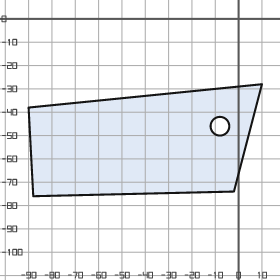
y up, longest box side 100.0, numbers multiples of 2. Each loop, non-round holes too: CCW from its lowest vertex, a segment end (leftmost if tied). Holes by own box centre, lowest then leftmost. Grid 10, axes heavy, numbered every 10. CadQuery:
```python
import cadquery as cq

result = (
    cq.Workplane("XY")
    .moveTo(-88.0, -76.0)
    .lineTo(-2.0, -74.0)
    .lineTo(10.0, -28.0)
    .lineTo(-90.0, -38.0)
    .close()
    .moveTo(-8.0, -46.0)
    .circle(4.0)
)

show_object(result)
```